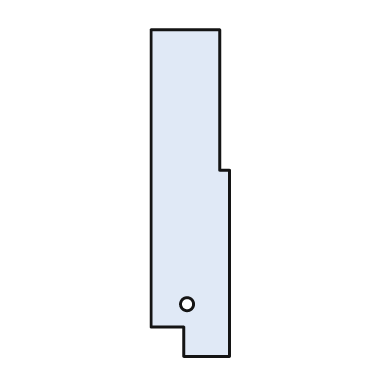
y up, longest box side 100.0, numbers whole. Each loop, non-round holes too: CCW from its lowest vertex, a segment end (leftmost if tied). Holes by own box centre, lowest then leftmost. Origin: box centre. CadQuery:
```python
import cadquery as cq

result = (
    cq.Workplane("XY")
    .moveTo(-2.0, -50.0)
    .lineTo(12.0, -50.0)
    .lineTo(12.0, 7.0)
    .lineTo(9.0, 7.0)
    .lineTo(9.0, 50.0)
    .lineTo(-12.0, 50.0)
    .lineTo(-12.0, -41.0)
    .lineTo(-2.0, -41.0)
    .close()
    .moveTo(-1.0, -34.0)
    .circle(2.0)
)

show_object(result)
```